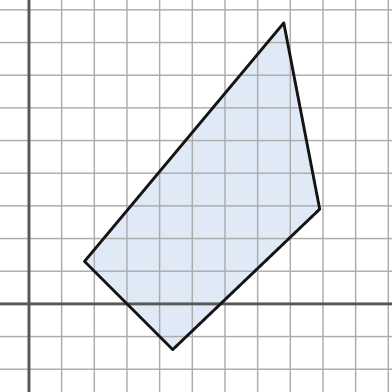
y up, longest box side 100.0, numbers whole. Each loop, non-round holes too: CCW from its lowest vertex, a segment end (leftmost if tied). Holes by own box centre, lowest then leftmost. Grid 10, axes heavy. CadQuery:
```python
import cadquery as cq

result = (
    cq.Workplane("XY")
    .moveTo(44.0, -14.0)
    .lineTo(89.0, 29.0)
    .lineTo(78.0, 86.0)
    .lineTo(17.0, 13.0)
    .close()
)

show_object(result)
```